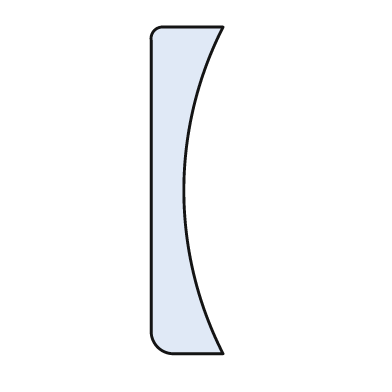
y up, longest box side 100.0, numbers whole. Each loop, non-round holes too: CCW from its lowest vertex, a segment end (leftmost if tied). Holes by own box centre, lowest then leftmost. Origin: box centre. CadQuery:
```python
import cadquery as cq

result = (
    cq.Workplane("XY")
    .moveTo(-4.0, -50.0)
    .lineTo(11.0, -50.0)
    .threePointArc((-1.0, 0.0), (11.0, 50.0))
    .lineTo(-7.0, 50.0)
    .threePointArc((-10.0, 49.0), (-11.0, 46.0))
    .lineTo(-11.0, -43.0)
    .threePointArc((-9.0, -48.0), (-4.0, -50.0))
    .close()
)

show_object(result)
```